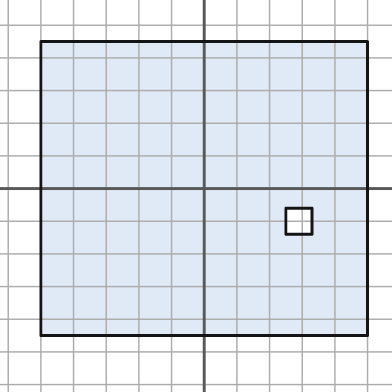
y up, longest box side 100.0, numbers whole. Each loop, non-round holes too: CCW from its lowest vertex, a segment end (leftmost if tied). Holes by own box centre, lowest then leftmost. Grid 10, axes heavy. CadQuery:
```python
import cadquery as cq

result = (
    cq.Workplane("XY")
    .moveTo(-50.0, -45.0)
    .lineTo(50.0, -45.0)
    .lineTo(50.0, 45.0)
    .lineTo(-50.0, 45.0)
    .close()
    .moveTo(25.0, -14.0)
    .lineTo(33.0, -14.0)
    .lineTo(33.0, -6.0)
    .lineTo(25.0, -6.0)
    .close()
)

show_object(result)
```